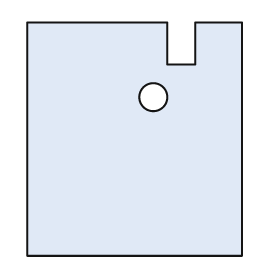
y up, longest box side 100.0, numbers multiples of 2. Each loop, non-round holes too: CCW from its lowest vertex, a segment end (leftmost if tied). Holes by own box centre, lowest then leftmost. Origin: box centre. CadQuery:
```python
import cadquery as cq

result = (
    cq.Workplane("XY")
    .moveTo(-46.0, -50.0)
    .lineTo(46.0, -50.0)
    .lineTo(46.0, 50.0)
    .lineTo(26.0, 50.0)
    .lineTo(26.0, 32.0)
    .lineTo(14.0, 32.0)
    .lineTo(14.0, 50.0)
    .lineTo(-46.0, 50.0)
    .close()
    .moveTo(8.0, 18.0)
    .circle(6.0)
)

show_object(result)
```